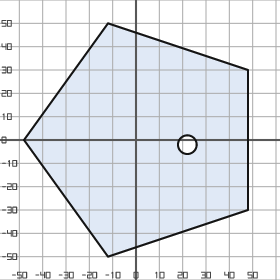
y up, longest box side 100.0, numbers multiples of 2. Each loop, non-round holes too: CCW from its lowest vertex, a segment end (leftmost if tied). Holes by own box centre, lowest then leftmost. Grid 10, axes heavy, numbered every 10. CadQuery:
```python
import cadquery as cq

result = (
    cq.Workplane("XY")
    .moveTo(-12.0, -50.0)
    .lineTo(48.0, -30.0)
    .lineTo(48.0, 30.0)
    .lineTo(-12.0, 50.0)
    .lineTo(-48.0, 0.0)
    .close()
    .moveTo(22.0, -2.0)
    .circle(4.0)
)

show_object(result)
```